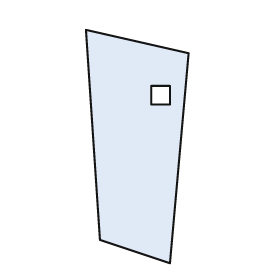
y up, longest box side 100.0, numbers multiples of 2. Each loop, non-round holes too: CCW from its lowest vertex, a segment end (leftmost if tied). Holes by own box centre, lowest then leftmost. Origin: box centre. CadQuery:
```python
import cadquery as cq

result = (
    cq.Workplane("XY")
    .moveTo(14.0, -50.0)
    .lineTo(22.0, 40.0)
    .lineTo(-22.0, 50.0)
    .lineTo(-16.0, -40.0)
    .close()
    .moveTo(6.0, 18.0)
    .lineTo(14.0, 18.0)
    .lineTo(14.0, 26.0)
    .lineTo(6.0, 26.0)
    .close()
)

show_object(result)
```